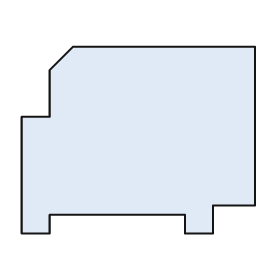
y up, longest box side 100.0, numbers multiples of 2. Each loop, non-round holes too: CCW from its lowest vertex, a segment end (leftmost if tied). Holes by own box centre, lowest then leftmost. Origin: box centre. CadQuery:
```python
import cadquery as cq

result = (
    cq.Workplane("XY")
    .moveTo(-50.0, -40.0)
    .lineTo(-38.0, -40.0)
    .lineTo(-38.0, -32.0)
    .lineTo(20.0, -32.0)
    .lineTo(20.0, -40.0)
    .lineTo(32.0, -40.0)
    .lineTo(32.0, -28.0)
    .lineTo(50.0, -28.0)
    .lineTo(50.0, 40.0)
    .lineTo(-28.0, 40.0)
    .lineTo(-38.0, 30.0)
    .lineTo(-38.0, 10.0)
    .lineTo(-50.0, 10.0)
    .close()
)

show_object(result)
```